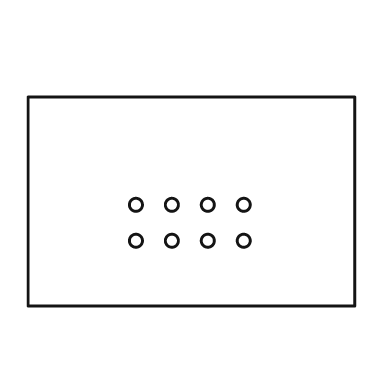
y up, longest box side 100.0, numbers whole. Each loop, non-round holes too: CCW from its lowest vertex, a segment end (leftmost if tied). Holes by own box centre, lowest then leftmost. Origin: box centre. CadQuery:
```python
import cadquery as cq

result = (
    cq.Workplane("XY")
    .moveTo(-50.0, -32.0)
    .lineTo(50.0, -32.0)
    .lineTo(50.0, 32.0)
    .lineTo(-50.0, 32.0)
    .close()
    .moveTo(-17.0, -12.0)
    .circle(2.0)
    .moveTo(-6.0, -12.0)
    .circle(2.0)
    .moveTo(5.0, -12.0)
    .circle(2.0)
    .moveTo(16.0, -12.0)
    .circle(2.0)
    .moveTo(-17.0, -1.0)
    .circle(2.0)
    .moveTo(-6.0, -1.0)
    .circle(2.0)
    .moveTo(5.0, -1.0)
    .circle(2.0)
    .moveTo(16.0, -1.0)
    .circle(2.0)
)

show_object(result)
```